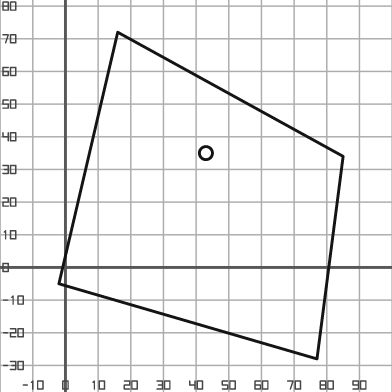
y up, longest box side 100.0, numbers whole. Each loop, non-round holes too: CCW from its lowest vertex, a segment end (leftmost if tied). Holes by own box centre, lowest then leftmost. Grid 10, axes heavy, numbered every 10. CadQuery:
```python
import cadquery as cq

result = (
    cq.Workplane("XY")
    .moveTo(77.0, -28.0)
    .lineTo(85.0, 34.0)
    .lineTo(16.0, 72.0)
    .lineTo(-2.0, -5.0)
    .close()
    .moveTo(43.0, 35.0)
    .circle(2.0)
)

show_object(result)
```